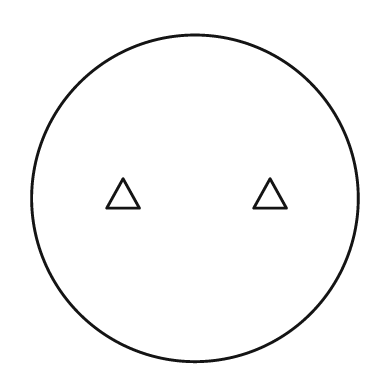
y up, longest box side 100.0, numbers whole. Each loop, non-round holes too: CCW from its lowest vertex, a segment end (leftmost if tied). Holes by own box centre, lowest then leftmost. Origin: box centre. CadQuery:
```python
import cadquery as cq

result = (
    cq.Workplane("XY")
    .moveTo(0.0, 0.0)
    .circle(50.0)
    .moveTo(-27.0, -3.0)
    .lineTo(-17.0, -3.0)
    .lineTo(-22.0, 6.0)
    .close()
    .moveTo(18.0, -3.0)
    .lineTo(28.0, -3.0)
    .lineTo(23.0, 6.0)
    .close()
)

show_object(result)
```